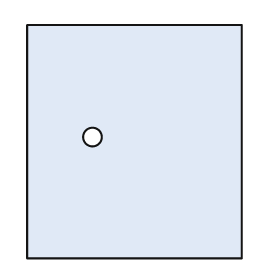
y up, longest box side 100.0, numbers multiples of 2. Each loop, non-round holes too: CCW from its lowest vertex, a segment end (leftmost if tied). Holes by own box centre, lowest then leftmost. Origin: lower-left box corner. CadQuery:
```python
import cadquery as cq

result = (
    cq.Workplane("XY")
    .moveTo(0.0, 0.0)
    .lineTo(92.0, 0.0)
    .lineTo(92.0, 100.0)
    .lineTo(0.0, 100.0)
    .close()
    .moveTo(28.0, 52.0)
    .circle(4.0)
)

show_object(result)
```